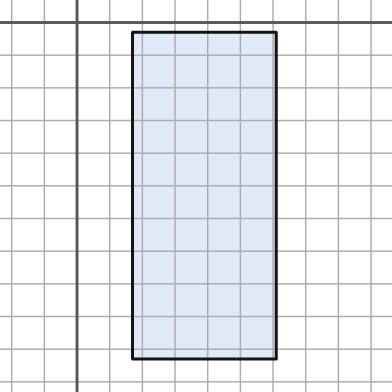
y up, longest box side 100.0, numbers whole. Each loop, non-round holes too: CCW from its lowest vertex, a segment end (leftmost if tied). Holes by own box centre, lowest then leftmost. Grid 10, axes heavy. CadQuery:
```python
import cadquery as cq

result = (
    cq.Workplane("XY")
    .moveTo(17.0, -103.0)
    .lineTo(61.0, -103.0)
    .lineTo(61.0, -3.0)
    .lineTo(17.0, -3.0)
    .close()
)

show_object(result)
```